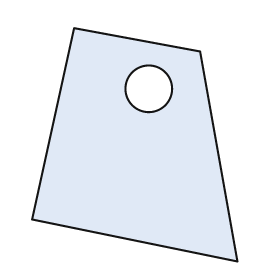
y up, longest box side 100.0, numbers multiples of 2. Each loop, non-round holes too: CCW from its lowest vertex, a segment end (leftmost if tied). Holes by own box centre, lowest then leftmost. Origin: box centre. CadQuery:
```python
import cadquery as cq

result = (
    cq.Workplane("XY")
    .moveTo(44.0, -50.0)
    .lineTo(28.0, 40.0)
    .lineTo(-26.0, 50.0)
    .lineTo(-44.0, -32.0)
    .close()
    .moveTo(6.0, 24.0)
    .circle(10.0)
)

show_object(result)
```